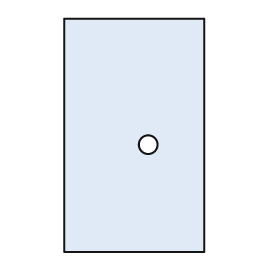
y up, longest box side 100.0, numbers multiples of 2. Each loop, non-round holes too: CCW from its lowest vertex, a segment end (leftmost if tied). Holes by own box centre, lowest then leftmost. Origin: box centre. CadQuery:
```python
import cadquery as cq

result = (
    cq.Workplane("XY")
    .moveTo(-30.0, -50.0)
    .lineTo(30.0, -50.0)
    .lineTo(30.0, 50.0)
    .lineTo(-30.0, 50.0)
    .close()
    .moveTo(6.0, -4.0)
    .circle(4.0)
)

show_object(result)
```